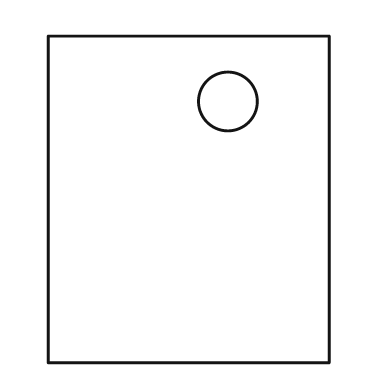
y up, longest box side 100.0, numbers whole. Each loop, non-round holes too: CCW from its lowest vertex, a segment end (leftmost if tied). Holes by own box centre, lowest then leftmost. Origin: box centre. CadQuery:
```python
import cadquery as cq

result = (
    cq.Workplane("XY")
    .moveTo(-43.0, -50.0)
    .lineTo(43.0, -50.0)
    .lineTo(43.0, 50.0)
    .lineTo(-43.0, 50.0)
    .close()
    .moveTo(12.0, 30.0)
    .circle(9.0)
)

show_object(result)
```